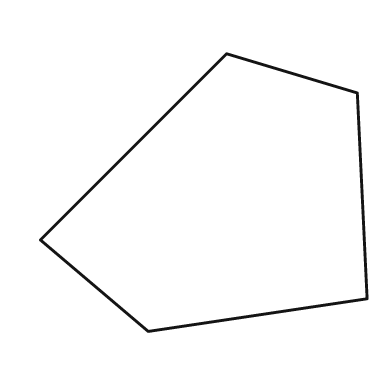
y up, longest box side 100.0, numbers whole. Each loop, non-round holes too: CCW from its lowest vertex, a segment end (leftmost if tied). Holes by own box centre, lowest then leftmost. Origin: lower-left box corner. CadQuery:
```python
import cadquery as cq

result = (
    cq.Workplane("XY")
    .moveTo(33.0, 0.0)
    .lineTo(100.0, 10.0)
    .lineTo(97.0, 73.0)
    .lineTo(57.0, 85.0)
    .lineTo(0.0, 28.0)
    .close()
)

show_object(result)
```